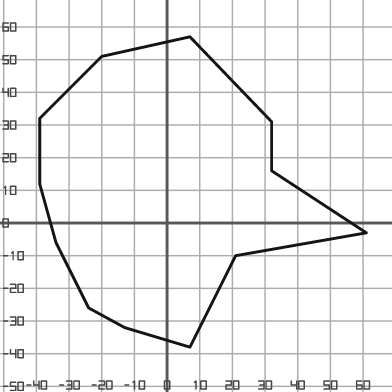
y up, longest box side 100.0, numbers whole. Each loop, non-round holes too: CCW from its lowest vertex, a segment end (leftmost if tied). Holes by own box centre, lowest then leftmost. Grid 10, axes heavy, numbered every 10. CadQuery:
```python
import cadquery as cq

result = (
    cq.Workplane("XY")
    .moveTo(7.0, -38.0)
    .lineTo(21.0, -10.0)
    .lineTo(61.0, -3.0)
    .lineTo(32.0, 16.0)
    .lineTo(32.0, 31.0)
    .lineTo(7.0, 57.0)
    .lineTo(-20.0, 51.0)
    .lineTo(-39.0, 32.0)
    .lineTo(-39.0, 12.0)
    .lineTo(-34.0, -6.0)
    .lineTo(-24.0, -26.0)
    .lineTo(-13.0, -32.0)
    .close()
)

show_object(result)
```